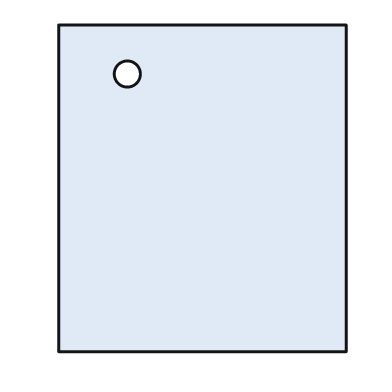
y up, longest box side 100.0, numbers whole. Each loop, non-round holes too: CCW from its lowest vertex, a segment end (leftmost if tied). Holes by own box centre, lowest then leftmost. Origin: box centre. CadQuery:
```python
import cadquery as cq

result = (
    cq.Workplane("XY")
    .moveTo(-44.0, -50.0)
    .lineTo(44.0, -50.0)
    .lineTo(44.0, 50.0)
    .lineTo(-44.0, 50.0)
    .close()
    .moveTo(-23.0, 35.0)
    .circle(4.0)
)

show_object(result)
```